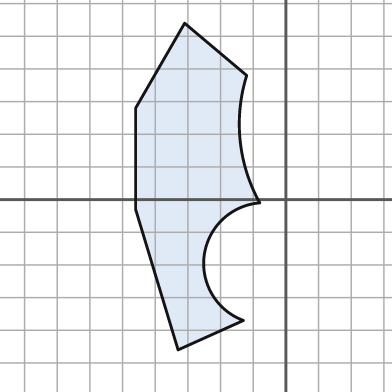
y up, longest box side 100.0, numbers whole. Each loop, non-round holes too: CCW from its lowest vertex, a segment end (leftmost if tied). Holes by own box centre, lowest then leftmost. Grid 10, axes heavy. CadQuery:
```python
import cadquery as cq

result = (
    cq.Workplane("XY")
    .moveTo(-33.0, -46.0)
    .lineTo(-13.0, -37.0)
    .threePointArc((-25.0, -17.0), (-8.0, -1.0))
    .threePointArc((-14.0, 18.0), (-12.0, 38.0))
    .lineTo(-31.0, 54.0)
    .lineTo(-46.0, 28.0)
    .lineTo(-46.0, -3.0)
    .close()
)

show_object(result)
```